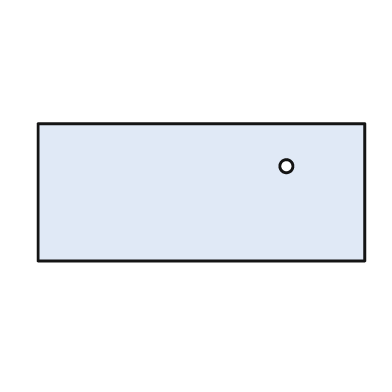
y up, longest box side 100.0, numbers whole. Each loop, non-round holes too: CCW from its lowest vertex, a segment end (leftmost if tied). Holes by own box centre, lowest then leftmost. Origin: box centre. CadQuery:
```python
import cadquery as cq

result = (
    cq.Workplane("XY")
    .moveTo(-50.0, -21.0)
    .lineTo(50.0, -21.0)
    .lineTo(50.0, 21.0)
    .lineTo(-50.0, 21.0)
    .close()
    .moveTo(26.0, 8.0)
    .circle(2.0)
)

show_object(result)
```